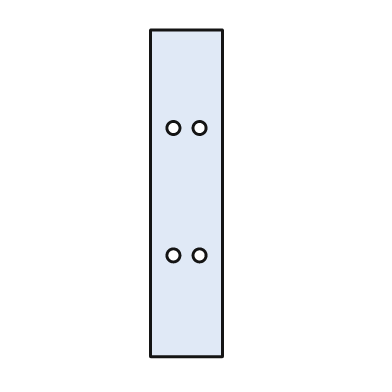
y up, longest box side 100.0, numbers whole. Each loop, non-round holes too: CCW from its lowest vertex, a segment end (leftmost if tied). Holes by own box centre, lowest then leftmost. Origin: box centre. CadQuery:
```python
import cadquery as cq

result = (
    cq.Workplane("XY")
    .moveTo(-11.0, -50.0)
    .lineTo(11.0, -50.0)
    .lineTo(11.0, 50.0)
    .lineTo(-11.0, 50.0)
    .close()
    .moveTo(-4.0, -19.0)
    .circle(2.0)
    .moveTo(4.0, -19.0)
    .circle(2.0)
    .moveTo(-4.0, 20.0)
    .circle(2.0)
    .moveTo(4.0, 20.0)
    .circle(2.0)
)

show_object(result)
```